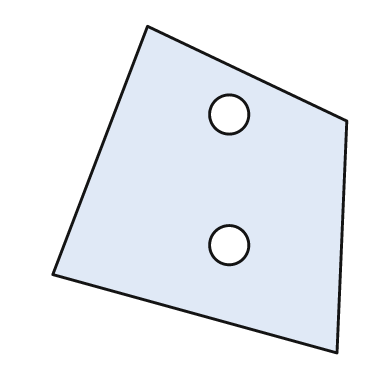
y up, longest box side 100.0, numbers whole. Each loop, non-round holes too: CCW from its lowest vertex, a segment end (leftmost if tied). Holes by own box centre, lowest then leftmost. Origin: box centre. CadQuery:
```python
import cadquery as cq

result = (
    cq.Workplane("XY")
    .moveTo(42.0, -50.0)
    .lineTo(45.0, 21.0)
    .lineTo(-16.0, 50.0)
    .lineTo(-45.0, -26.0)
    .close()
    .moveTo(9.0, -17.0)
    .circle(6.0)
    .moveTo(9.0, 23.0)
    .circle(6.0)
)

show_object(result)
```